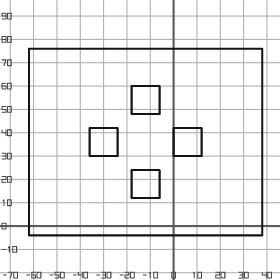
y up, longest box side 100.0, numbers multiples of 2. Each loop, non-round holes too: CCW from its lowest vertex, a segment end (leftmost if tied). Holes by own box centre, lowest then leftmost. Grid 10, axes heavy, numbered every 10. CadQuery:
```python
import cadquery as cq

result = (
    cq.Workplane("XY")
    .moveTo(-62.0, -4.0)
    .lineTo(38.0, -4.0)
    .lineTo(38.0, 76.0)
    .lineTo(-62.0, 76.0)
    .close()
    .moveTo(-18.0, 12.0)
    .lineTo(-6.0, 12.0)
    .lineTo(-6.0, 24.0)
    .lineTo(-18.0, 24.0)
    .close()
    .moveTo(-36.0, 30.0)
    .lineTo(-24.0, 30.0)
    .lineTo(-24.0, 42.0)
    .lineTo(-36.0, 42.0)
    .close()
    .moveTo(0.0, 30.0)
    .lineTo(12.0, 30.0)
    .lineTo(12.0, 42.0)
    .lineTo(0.0, 42.0)
    .close()
    .moveTo(-18.0, 48.0)
    .lineTo(-6.0, 48.0)
    .lineTo(-6.0, 60.0)
    .lineTo(-18.0, 60.0)
    .close()
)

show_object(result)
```